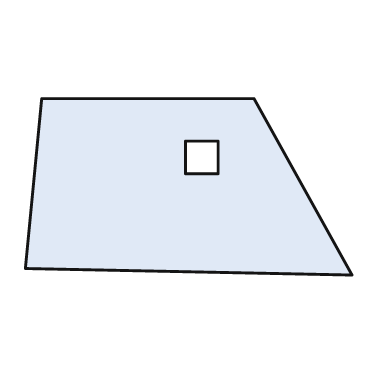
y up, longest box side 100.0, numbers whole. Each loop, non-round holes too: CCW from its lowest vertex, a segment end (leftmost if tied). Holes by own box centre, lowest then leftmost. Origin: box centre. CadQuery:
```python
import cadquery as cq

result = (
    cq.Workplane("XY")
    .moveTo(50.0, -27.0)
    .lineTo(20.0, 27.0)
    .lineTo(-45.0, 27.0)
    .lineTo(-50.0, -25.0)
    .close()
    .moveTo(-1.0, 4.0)
    .lineTo(9.0, 4.0)
    .lineTo(9.0, 14.0)
    .lineTo(-1.0, 14.0)
    .close()
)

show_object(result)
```